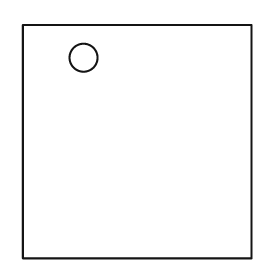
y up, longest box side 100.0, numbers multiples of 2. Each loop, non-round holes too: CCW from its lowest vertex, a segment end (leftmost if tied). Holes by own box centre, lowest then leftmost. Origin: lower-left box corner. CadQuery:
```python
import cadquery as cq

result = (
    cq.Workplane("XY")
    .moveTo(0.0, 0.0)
    .lineTo(98.0, 0.0)
    .lineTo(98.0, 100.0)
    .lineTo(0.0, 100.0)
    .close()
    .moveTo(26.0, 86.0)
    .circle(6.0)
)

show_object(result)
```